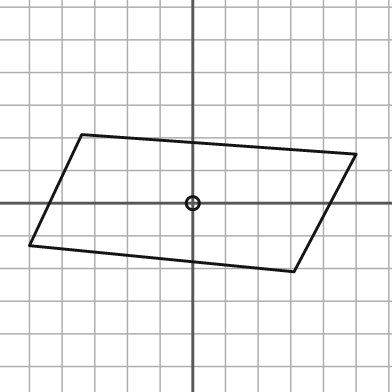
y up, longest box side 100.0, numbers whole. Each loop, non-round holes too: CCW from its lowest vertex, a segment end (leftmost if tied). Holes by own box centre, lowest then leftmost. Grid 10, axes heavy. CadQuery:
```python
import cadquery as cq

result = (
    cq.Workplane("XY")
    .moveTo(31.0, -21.0)
    .lineTo(50.0, 15.0)
    .lineTo(-34.0, 21.0)
    .lineTo(-50.0, -13.0)
    .close()
    .moveTo(0.0, 0.0)
    .circle(2.0)
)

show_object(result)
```